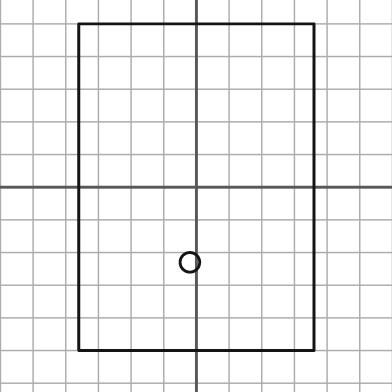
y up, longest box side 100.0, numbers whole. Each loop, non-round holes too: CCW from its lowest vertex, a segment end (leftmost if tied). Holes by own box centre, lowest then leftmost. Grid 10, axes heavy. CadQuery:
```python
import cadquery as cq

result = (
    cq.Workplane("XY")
    .moveTo(-36.0, -50.0)
    .lineTo(36.0, -50.0)
    .lineTo(36.0, 50.0)
    .lineTo(-36.0, 50.0)
    .close()
    .moveTo(-2.0, -23.0)
    .circle(3.0)
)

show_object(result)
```